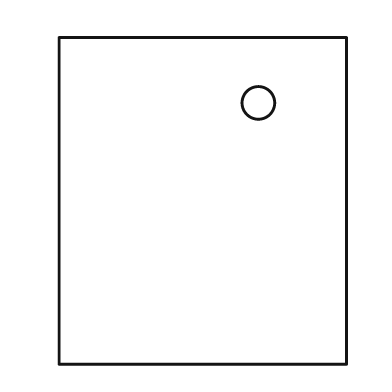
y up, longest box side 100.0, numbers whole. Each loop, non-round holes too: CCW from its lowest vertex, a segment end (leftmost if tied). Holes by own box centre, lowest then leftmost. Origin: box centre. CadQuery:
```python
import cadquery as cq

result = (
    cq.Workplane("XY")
    .moveTo(-44.0, -50.0)
    .lineTo(44.0, -50.0)
    .lineTo(44.0, 50.0)
    .lineTo(-44.0, 50.0)
    .close()
    .moveTo(17.0, 30.0)
    .circle(5.0)
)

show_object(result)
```